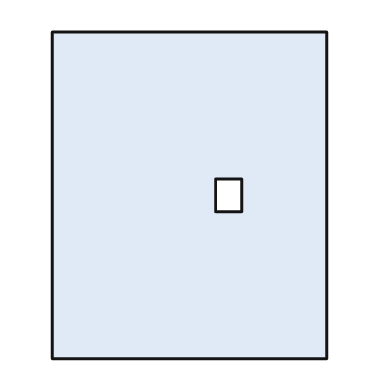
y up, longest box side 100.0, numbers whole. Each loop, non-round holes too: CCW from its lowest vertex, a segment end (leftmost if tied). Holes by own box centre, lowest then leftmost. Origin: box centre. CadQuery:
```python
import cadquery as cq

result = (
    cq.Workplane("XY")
    .moveTo(-42.0, -50.0)
    .lineTo(42.0, -50.0)
    .lineTo(42.0, 50.0)
    .lineTo(-42.0, 50.0)
    .close()
    .moveTo(8.0, -5.0)
    .lineTo(16.0, -5.0)
    .lineTo(16.0, 5.0)
    .lineTo(8.0, 5.0)
    .close()
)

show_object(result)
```